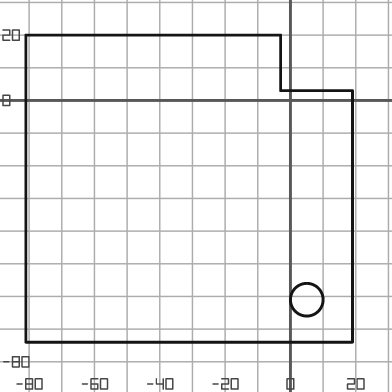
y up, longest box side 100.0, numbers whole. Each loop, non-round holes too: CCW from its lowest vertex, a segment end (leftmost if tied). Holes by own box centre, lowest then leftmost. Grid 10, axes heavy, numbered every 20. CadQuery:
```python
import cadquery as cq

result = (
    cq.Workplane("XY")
    .moveTo(-81.0, -74.0)
    .lineTo(19.0, -74.0)
    .lineTo(19.0, 3.0)
    .lineTo(-3.0, 3.0)
    .lineTo(-3.0, 20.0)
    .lineTo(-81.0, 20.0)
    .close()
    .moveTo(5.0, -61.0)
    .circle(5.0)
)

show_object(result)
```